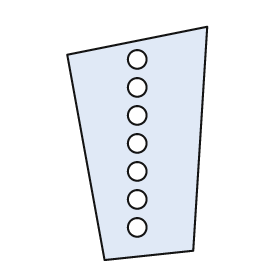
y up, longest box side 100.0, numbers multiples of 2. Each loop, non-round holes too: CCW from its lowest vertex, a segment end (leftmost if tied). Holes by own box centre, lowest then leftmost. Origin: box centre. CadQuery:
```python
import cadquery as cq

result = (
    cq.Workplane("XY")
    .moveTo(-14.0, -50.0)
    .lineTo(24.0, -46.0)
    .lineTo(30.0, 50.0)
    .lineTo(-30.0, 38.0)
    .close()
    .moveTo(0.0, -36.0)
    .circle(4.0)
    .moveTo(0.0, -24.0)
    .circle(4.0)
    .moveTo(0.0, -12.0)
    .circle(4.0)
    .moveTo(0.0, 0.0)
    .circle(4.0)
    .moveTo(0.0, 12.0)
    .circle(4.0)
    .moveTo(0.0, 24.0)
    .circle(4.0)
    .moveTo(0.0, 36.0)
    .circle(4.0)
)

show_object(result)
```